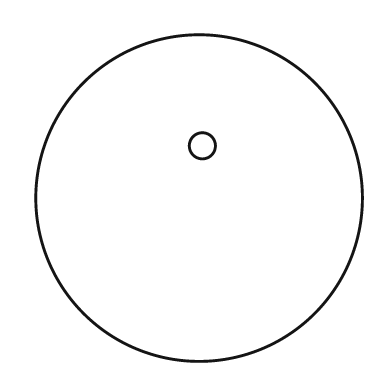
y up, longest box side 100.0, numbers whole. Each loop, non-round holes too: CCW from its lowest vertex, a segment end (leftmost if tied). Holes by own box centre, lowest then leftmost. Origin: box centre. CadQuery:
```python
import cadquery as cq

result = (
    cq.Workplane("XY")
    .moveTo(0.0, 0.0)
    .circle(50.0)
    .moveTo(1.0, 16.0)
    .circle(4.0)
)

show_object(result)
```